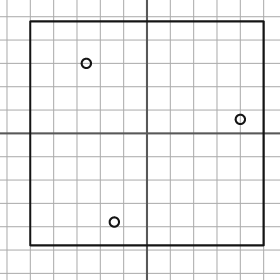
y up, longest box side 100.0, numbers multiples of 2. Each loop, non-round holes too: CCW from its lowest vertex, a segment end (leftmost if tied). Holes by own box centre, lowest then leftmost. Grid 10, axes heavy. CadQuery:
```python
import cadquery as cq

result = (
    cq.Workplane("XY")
    .moveTo(-50.0, -48.0)
    .lineTo(50.0, -48.0)
    .lineTo(50.0, 48.0)
    .lineTo(-50.0, 48.0)
    .close()
    .moveTo(-14.0, -38.0)
    .circle(2.0)
    .moveTo(40.0, 6.0)
    .circle(2.0)
    .moveTo(-26.0, 30.0)
    .circle(2.0)
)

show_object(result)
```